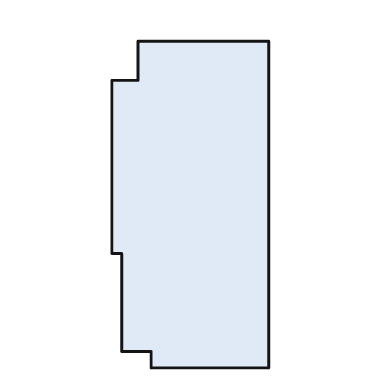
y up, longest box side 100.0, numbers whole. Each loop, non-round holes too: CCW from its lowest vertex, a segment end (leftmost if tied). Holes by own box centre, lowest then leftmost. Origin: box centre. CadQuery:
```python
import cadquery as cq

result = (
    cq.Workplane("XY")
    .moveTo(-12.0, -50.0)
    .lineTo(24.0, -50.0)
    .lineTo(24.0, 50.0)
    .lineTo(-16.0, 50.0)
    .lineTo(-16.0, 38.0)
    .lineTo(-24.0, 38.0)
    .lineTo(-24.0, -15.0)
    .lineTo(-21.0, -15.0)
    .lineTo(-21.0, -45.0)
    .lineTo(-12.0, -45.0)
    .close()
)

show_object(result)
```